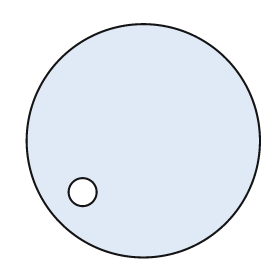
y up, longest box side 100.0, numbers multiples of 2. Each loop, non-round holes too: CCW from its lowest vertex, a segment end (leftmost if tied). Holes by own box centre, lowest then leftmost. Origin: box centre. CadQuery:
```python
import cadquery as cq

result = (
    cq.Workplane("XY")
    .moveTo(0.0, 0.0)
    .circle(50.0)
    .moveTo(-26.0, -22.0)
    .circle(6.0)
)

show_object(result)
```